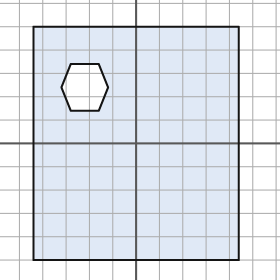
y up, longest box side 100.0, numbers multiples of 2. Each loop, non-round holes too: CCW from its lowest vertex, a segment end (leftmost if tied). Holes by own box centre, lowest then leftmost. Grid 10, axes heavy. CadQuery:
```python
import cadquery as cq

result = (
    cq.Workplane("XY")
    .moveTo(-44.0, -50.0)
    .lineTo(44.0, -50.0)
    .lineTo(44.0, 50.0)
    .lineTo(-44.0, 50.0)
    .close()
    .moveTo(-28.0, 14.0)
    .lineTo(-16.0, 14.0)
    .lineTo(-12.0, 24.0)
    .lineTo(-16.0, 34.0)
    .lineTo(-28.0, 34.0)
    .lineTo(-32.0, 24.0)
    .close()
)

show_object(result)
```